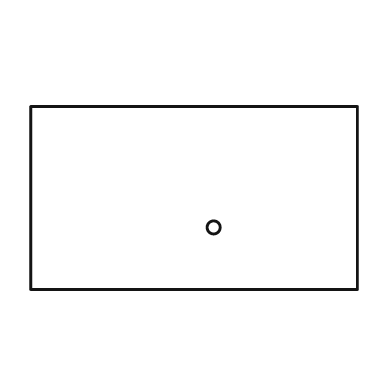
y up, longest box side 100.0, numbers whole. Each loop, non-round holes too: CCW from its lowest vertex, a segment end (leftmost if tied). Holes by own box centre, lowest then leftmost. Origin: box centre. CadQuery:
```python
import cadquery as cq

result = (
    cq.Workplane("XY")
    .moveTo(-50.0, -28.0)
    .lineTo(50.0, -28.0)
    .lineTo(50.0, 28.0)
    .lineTo(-50.0, 28.0)
    .close()
    .moveTo(6.0, -9.0)
    .circle(2.0)
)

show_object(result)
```